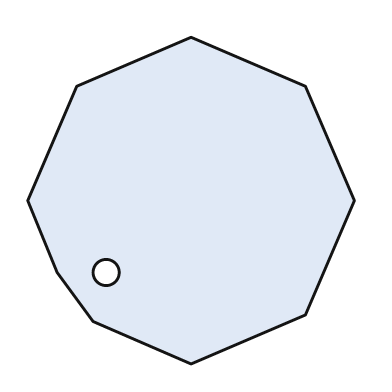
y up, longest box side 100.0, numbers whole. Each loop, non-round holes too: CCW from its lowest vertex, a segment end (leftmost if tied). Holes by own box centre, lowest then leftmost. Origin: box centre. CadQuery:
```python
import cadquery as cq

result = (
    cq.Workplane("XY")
    .moveTo(0.0, -50.0)
    .lineTo(35.0, -35.0)
    .lineTo(50.0, 0.0)
    .lineTo(35.0, 35.0)
    .lineTo(0.0, 50.0)
    .lineTo(-35.0, 35.0)
    .lineTo(-50.0, 0.0)
    .lineTo(-41.0, -22.0)
    .lineTo(-30.0, -37.0)
    .close()
    .moveTo(-26.0, -22.0)
    .circle(4.0)
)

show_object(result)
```